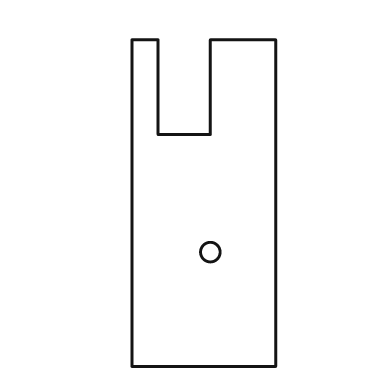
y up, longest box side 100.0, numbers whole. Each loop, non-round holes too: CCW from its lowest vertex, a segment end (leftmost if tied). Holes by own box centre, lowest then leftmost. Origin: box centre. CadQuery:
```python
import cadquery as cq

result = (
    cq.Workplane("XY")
    .moveTo(-22.0, -50.0)
    .lineTo(22.0, -50.0)
    .lineTo(22.0, 50.0)
    .lineTo(2.0, 50.0)
    .lineTo(2.0, 21.0)
    .lineTo(-14.0, 21.0)
    .lineTo(-14.0, 50.0)
    .lineTo(-22.0, 50.0)
    .close()
    .moveTo(2.0, -15.0)
    .circle(3.0)
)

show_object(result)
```